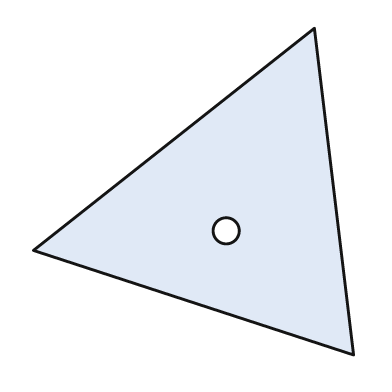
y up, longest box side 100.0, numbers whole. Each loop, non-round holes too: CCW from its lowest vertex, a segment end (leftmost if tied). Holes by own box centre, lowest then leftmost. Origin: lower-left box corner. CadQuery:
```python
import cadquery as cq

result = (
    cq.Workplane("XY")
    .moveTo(98.0, 0.0)
    .lineTo(86.0, 100.0)
    .lineTo(0.0, 32.0)
    .close()
    .moveTo(59.0, 38.0)
    .circle(4.0)
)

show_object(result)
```